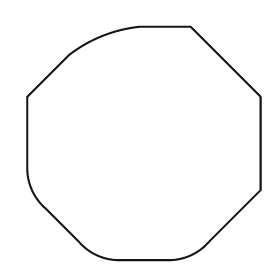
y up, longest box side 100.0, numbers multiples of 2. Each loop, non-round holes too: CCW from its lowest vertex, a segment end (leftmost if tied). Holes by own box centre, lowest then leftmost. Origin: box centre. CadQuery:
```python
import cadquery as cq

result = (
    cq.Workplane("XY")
    .moveTo(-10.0, -50.0)
    .lineTo(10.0, -50.0)
    .threePointArc((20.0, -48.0), (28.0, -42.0))
    .lineTo(50.0, -20.0)
    .lineTo(50.0, 20.0)
    .lineTo(20.0, 50.0)
    .lineTo(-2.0, 50.0)
    .threePointArc((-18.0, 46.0), (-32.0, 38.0))
    .lineTo(-50.0, 20.0)
    .lineTo(-50.0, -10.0)
    .threePointArc((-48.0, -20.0), (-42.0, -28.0))
    .lineTo(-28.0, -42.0)
    .threePointArc((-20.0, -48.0), (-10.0, -50.0))
    .close()
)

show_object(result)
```